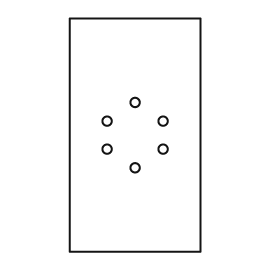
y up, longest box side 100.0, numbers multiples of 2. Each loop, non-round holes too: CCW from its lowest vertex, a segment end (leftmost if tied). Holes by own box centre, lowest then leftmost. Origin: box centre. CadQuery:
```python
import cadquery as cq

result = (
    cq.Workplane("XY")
    .moveTo(-28.0, -50.0)
    .lineTo(28.0, -50.0)
    .lineTo(28.0, 50.0)
    .lineTo(-28.0, 50.0)
    .close()
    .moveTo(0.0, -14.0)
    .circle(2.0)
    .moveTo(-12.0, -6.0)
    .circle(2.0)
    .moveTo(12.0, -6.0)
    .circle(2.0)
    .moveTo(-12.0, 6.0)
    .circle(2.0)
    .moveTo(12.0, 6.0)
    .circle(2.0)
    .moveTo(0.0, 14.0)
    .circle(2.0)
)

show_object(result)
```